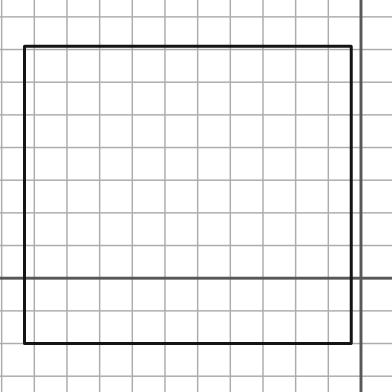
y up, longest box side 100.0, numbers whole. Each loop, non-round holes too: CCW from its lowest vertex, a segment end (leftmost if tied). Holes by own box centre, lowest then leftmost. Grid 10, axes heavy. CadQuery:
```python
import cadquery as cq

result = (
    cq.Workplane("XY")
    .moveTo(-103.0, -20.0)
    .lineTo(-3.0, -20.0)
    .lineTo(-3.0, 71.0)
    .lineTo(-103.0, 71.0)
    .close()
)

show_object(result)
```